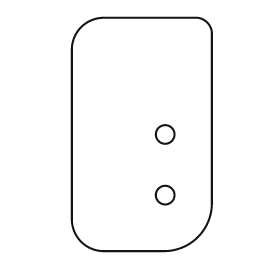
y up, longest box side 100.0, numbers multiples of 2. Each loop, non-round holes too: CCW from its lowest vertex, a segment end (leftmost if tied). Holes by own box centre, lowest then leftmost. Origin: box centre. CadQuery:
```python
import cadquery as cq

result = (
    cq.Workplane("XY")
    .moveTo(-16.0, -50.0)
    .lineTo(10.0, -50.0)
    .threePointArc((24.0, -44.0), (30.0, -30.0))
    .lineTo(30.0, 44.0)
    .threePointArc((28.0, 48.0), (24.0, 50.0))
    .lineTo(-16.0, 50.0)
    .threePointArc((-26.0, 46.0), (-30.0, 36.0))
    .lineTo(-30.0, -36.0)
    .threePointArc((-26.0, -46.0), (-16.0, -50.0))
    .close()
    .moveTo(10.0, -26.0)
    .circle(4.0)
    .moveTo(10.0, 0.0)
    .circle(4.0)
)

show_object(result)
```